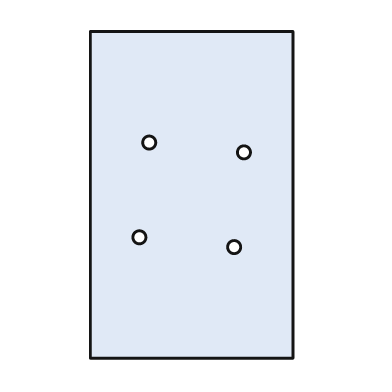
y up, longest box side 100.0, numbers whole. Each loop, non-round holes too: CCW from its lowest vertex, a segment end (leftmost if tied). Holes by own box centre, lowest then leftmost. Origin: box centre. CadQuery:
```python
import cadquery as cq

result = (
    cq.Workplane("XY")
    .moveTo(-31.0, -50.0)
    .lineTo(31.0, -50.0)
    .lineTo(31.0, 50.0)
    .lineTo(-31.0, 50.0)
    .close()
    .moveTo(13.0, -16.0)
    .circle(2.0)
    .moveTo(-16.0, -13.0)
    .circle(2.0)
    .moveTo(16.0, 13.0)
    .circle(2.0)
    .moveTo(-13.0, 16.0)
    .circle(2.0)
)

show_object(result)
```